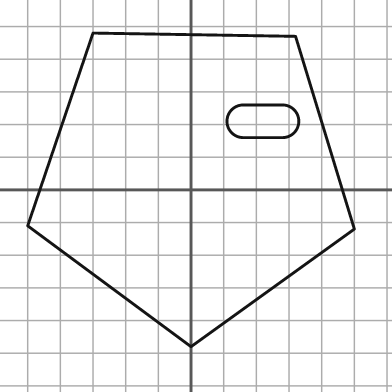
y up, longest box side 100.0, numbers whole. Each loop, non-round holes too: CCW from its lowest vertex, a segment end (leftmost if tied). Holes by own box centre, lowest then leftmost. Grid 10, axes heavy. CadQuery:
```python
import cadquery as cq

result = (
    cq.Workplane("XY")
    .moveTo(0.0, -48.0)
    .lineTo(50.0, -12.0)
    .lineTo(32.0, 47.0)
    .lineTo(-30.0, 48.0)
    .lineTo(-50.0, -11.0)
    .close()
    .moveTo(16.0, 16.0)
    .lineTo(28.0, 16.0)
    .threePointArc((33.0, 21.0), (28.0, 26.0))
    .lineTo(16.0, 26.0)
    .threePointArc((11.0, 21.0), (16.0, 16.0))
    .close()
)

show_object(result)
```